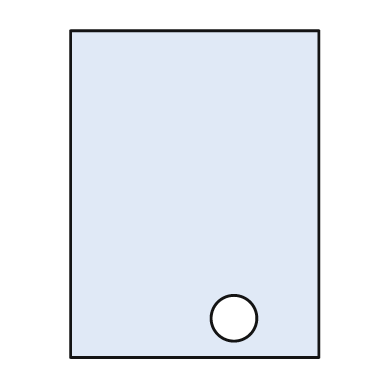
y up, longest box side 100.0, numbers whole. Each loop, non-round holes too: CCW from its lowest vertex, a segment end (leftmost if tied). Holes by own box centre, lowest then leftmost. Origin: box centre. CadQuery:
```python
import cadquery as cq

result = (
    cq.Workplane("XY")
    .moveTo(-38.0, -50.0)
    .lineTo(38.0, -50.0)
    .lineTo(38.0, 50.0)
    .lineTo(-38.0, 50.0)
    .close()
    .moveTo(12.0, -38.0)
    .circle(7.0)
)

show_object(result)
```